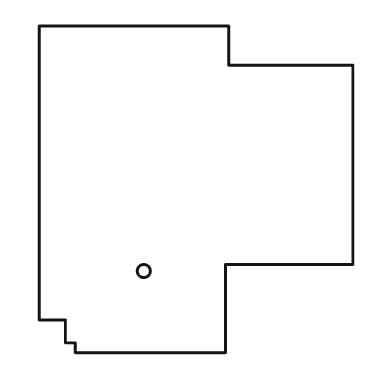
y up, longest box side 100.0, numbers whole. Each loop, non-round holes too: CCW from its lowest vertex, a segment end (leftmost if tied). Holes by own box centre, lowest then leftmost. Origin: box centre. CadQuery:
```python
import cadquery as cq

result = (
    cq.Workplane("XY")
    .moveTo(-37.0, -50.0)
    .lineTo(9.0, -50.0)
    .lineTo(9.0, -23.0)
    .lineTo(48.0, -23.0)
    .lineTo(48.0, 38.0)
    .lineTo(10.0, 38.0)
    .lineTo(10.0, 50.0)
    .lineTo(-48.0, 50.0)
    .lineTo(-48.0, -40.0)
    .lineTo(-40.0, -40.0)
    .lineTo(-40.0, -47.0)
    .lineTo(-37.0, -47.0)
    .close()
    .moveTo(-16.0, -25.0)
    .circle(2.0)
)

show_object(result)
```